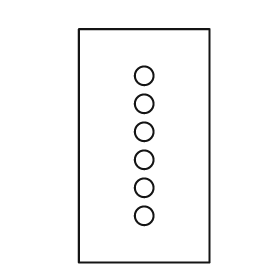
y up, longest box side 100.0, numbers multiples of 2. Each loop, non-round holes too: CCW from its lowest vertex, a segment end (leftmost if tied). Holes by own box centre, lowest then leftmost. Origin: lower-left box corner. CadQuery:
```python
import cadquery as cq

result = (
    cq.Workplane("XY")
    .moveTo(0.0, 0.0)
    .lineTo(56.0, 0.0)
    .lineTo(56.0, 100.0)
    .lineTo(0.0, 100.0)
    .close()
    .moveTo(28.0, 20.0)
    .circle(4.0)
    .moveTo(28.0, 32.0)
    .circle(4.0)
    .moveTo(28.0, 44.0)
    .circle(4.0)
    .moveTo(28.0, 56.0)
    .circle(4.0)
    .moveTo(28.0, 68.0)
    .circle(4.0)
    .moveTo(28.0, 80.0)
    .circle(4.0)
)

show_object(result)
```